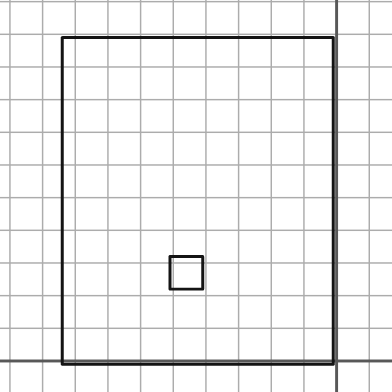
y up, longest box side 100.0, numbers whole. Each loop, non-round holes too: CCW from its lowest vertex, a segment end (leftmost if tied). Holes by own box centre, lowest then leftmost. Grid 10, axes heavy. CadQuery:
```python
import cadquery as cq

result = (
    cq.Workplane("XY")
    .moveTo(-84.0, -1.0)
    .lineTo(-1.0, -1.0)
    .lineTo(-1.0, 99.0)
    .lineTo(-84.0, 99.0)
    .close()
    .moveTo(-51.0, 22.0)
    .lineTo(-41.0, 22.0)
    .lineTo(-41.0, 32.0)
    .lineTo(-51.0, 32.0)
    .close()
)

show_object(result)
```